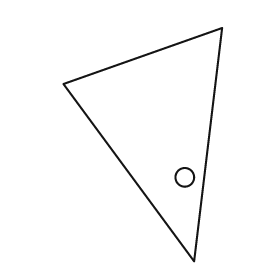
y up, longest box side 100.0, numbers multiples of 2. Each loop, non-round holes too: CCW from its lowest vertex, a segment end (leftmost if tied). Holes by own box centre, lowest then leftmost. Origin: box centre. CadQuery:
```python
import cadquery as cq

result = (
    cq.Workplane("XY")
    .moveTo(22.0, -50.0)
    .lineTo(34.0, 50.0)
    .lineTo(-34.0, 26.0)
    .close()
    .moveTo(18.0, -14.0)
    .circle(4.0)
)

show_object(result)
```